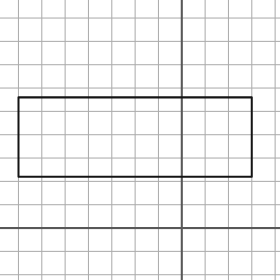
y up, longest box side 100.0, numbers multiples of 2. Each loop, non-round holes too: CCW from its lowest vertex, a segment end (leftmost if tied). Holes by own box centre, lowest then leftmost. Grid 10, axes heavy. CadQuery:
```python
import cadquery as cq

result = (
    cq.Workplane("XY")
    .moveTo(-70.0, 22.0)
    .lineTo(30.0, 22.0)
    .lineTo(30.0, 56.0)
    .lineTo(-70.0, 56.0)
    .close()
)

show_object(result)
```